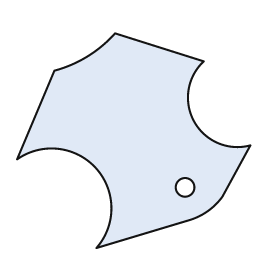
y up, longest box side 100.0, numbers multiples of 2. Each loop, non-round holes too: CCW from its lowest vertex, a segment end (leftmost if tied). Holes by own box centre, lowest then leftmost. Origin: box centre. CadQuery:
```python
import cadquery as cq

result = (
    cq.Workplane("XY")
    .moveTo(-16.0, -46.0)
    .lineTo(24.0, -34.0)
    .threePointArc((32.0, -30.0), (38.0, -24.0))
    .lineTo(50.0, -2.0)
    .threePointArc((26.0, 8.0), (30.0, 34.0))
    .lineTo(-8.0, 46.0)
    .threePointArc((-20.0, 36.0), (-34.0, 30.0))
    .lineTo(-50.0, -8.0)
    .threePointArc((-16.0, -12.0), (-16.0, -46.0))
    .close()
    .moveTo(22.0, -20.0)
    .circle(4.0)
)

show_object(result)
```